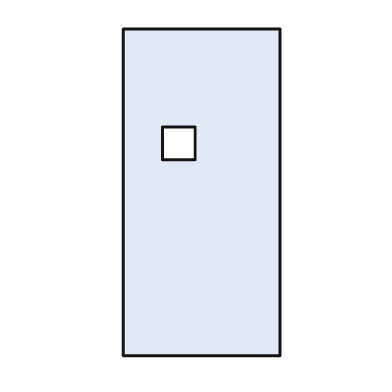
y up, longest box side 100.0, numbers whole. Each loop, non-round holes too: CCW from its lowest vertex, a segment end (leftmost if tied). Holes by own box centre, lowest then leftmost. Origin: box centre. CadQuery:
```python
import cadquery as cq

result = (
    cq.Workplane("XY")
    .moveTo(-24.0, -50.0)
    .lineTo(24.0, -50.0)
    .lineTo(24.0, 50.0)
    .lineTo(-24.0, 50.0)
    .close()
    .moveTo(-12.0, 10.0)
    .lineTo(-2.0, 10.0)
    .lineTo(-2.0, 20.0)
    .lineTo(-12.0, 20.0)
    .close()
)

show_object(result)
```